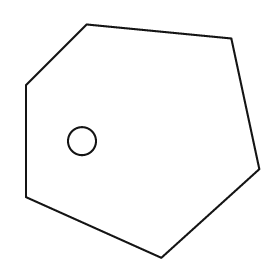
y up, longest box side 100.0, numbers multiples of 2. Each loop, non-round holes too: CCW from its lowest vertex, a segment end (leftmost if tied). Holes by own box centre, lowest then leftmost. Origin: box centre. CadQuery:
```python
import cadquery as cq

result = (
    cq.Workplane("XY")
    .moveTo(8.0, -50.0)
    .lineTo(50.0, -12.0)
    .lineTo(38.0, 44.0)
    .lineTo(-24.0, 50.0)
    .lineTo(-50.0, 24.0)
    .lineTo(-50.0, -24.0)
    .close()
    .moveTo(-26.0, 0.0)
    .circle(6.0)
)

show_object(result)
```